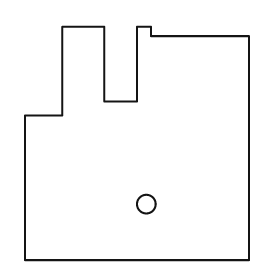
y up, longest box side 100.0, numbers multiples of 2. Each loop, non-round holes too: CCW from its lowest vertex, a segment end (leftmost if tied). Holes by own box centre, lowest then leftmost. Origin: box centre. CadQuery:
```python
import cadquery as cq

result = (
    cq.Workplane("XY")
    .moveTo(-48.0, -50.0)
    .lineTo(48.0, -50.0)
    .lineTo(48.0, 46.0)
    .lineTo(6.0, 46.0)
    .lineTo(6.0, 50.0)
    .lineTo(0.0, 50.0)
    .lineTo(0.0, 18.0)
    .lineTo(-14.0, 18.0)
    .lineTo(-14.0, 50.0)
    .lineTo(-32.0, 50.0)
    .lineTo(-32.0, 12.0)
    .lineTo(-48.0, 12.0)
    .close()
    .moveTo(4.0, -26.0)
    .circle(4.0)
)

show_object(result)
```